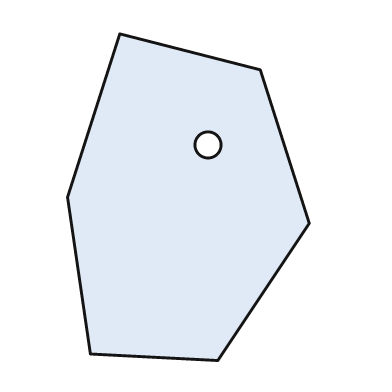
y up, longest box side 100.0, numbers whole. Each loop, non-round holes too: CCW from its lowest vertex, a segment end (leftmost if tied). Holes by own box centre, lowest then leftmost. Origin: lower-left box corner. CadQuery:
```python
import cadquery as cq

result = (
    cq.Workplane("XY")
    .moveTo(46.0, 0.0)
    .lineTo(74.0, 42.0)
    .lineTo(59.0, 89.0)
    .lineTo(16.0, 100.0)
    .lineTo(0.0, 50.0)
    .lineTo(7.0, 2.0)
    .close()
    .moveTo(43.0, 66.0)
    .circle(4.0)
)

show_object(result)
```